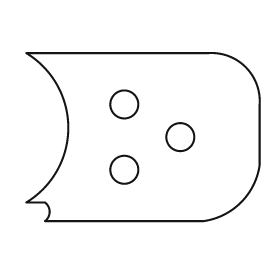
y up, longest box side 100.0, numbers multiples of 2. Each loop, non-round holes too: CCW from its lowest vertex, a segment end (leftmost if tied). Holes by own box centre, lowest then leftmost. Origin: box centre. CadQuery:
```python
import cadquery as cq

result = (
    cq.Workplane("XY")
    .moveTo(-42.0, -36.0)
    .lineTo(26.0, -36.0)
    .threePointArc((42.0, -28.0), (50.0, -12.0))
    .lineTo(50.0, 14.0)
    .threePointArc((44.0, 30.0), (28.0, 36.0))
    .lineTo(-50.0, 36.0)
    .threePointArc((-32.0, 4.0), (-50.0, -28.0))
    .lineTo(-42.0, -28.0)
    .threePointArc((-40.0, -32.0), (-42.0, -36.0))
    .close()
    .moveTo(-8.0, -14.0)
    .circle(6.0)
    .moveTo(16.0, 0.0)
    .circle(6.0)
    .moveTo(-8.0, 14.0)
    .circle(6.0)
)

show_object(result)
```